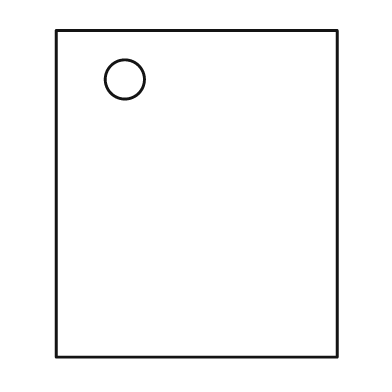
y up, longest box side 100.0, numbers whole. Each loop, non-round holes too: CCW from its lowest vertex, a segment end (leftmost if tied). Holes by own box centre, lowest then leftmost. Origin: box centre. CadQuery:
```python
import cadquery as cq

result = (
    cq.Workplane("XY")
    .moveTo(-43.0, -50.0)
    .lineTo(43.0, -50.0)
    .lineTo(43.0, 50.0)
    .lineTo(-43.0, 50.0)
    .close()
    .moveTo(-22.0, 35.0)
    .circle(6.0)
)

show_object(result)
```